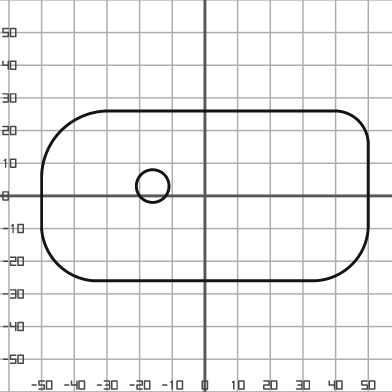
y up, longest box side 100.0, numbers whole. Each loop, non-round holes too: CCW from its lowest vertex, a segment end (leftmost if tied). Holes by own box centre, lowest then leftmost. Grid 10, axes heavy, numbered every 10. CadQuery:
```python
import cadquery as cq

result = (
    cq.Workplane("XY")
    .moveTo(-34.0, -26.0)
    .lineTo(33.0, -26.0)
    .threePointArc((45.0, -21.0), (50.0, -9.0))
    .lineTo(50.0, 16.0)
    .threePointArc((47.0, 23.0), (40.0, 26.0))
    .lineTo(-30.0, 26.0)
    .threePointArc((-44.0, 20.0), (-50.0, 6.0))
    .lineTo(-50.0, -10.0)
    .threePointArc((-45.0, -21.0), (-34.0, -26.0))
    .close()
    .moveTo(-16.0, 3.0)
    .circle(5.0)
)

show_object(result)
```